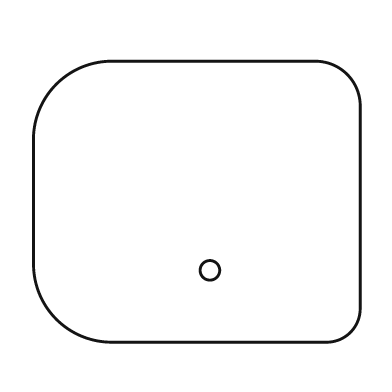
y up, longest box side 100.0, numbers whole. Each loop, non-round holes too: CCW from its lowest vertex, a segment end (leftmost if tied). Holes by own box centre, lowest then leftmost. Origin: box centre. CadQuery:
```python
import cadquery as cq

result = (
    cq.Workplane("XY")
    .moveTo(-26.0, -43.0)
    .lineTo(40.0, -43.0)
    .threePointArc((47.0, -40.0), (50.0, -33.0))
    .lineTo(50.0, 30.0)
    .threePointArc((46.0, 39.0), (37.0, 43.0))
    .lineTo(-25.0, 43.0)
    .threePointArc((-43.0, 36.0), (-50.0, 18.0))
    .lineTo(-50.0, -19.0)
    .threePointArc((-43.0, -36.0), (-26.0, -43.0))
    .close()
    .moveTo(4.0, -21.0)
    .circle(3.0)
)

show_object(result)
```